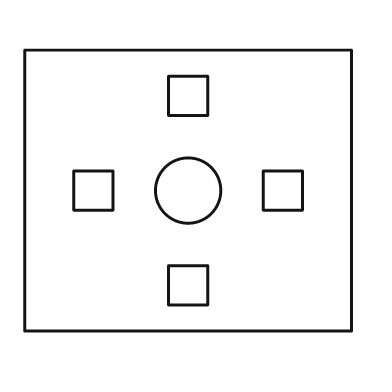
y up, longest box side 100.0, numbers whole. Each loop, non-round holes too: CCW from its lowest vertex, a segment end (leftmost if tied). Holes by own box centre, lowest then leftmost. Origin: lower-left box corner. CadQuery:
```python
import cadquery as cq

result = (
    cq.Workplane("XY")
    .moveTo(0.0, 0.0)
    .lineTo(100.0, 0.0)
    .lineTo(100.0, 86.0)
    .lineTo(0.0, 86.0)
    .close()
    .moveTo(44.0, 8.0)
    .lineTo(56.0, 8.0)
    .lineTo(56.0, 20.0)
    .lineTo(44.0, 20.0)
    .close()
    .moveTo(15.0, 37.0)
    .lineTo(27.0, 37.0)
    .lineTo(27.0, 49.0)
    .lineTo(15.0, 49.0)
    .close()
    .moveTo(50.0, 43.0)
    .circle(10.0)
    .moveTo(73.0, 37.0)
    .lineTo(85.0, 37.0)
    .lineTo(85.0, 49.0)
    .lineTo(73.0, 49.0)
    .close()
    .moveTo(44.0, 66.0)
    .lineTo(56.0, 66.0)
    .lineTo(56.0, 78.0)
    .lineTo(44.0, 78.0)
    .close()
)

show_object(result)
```